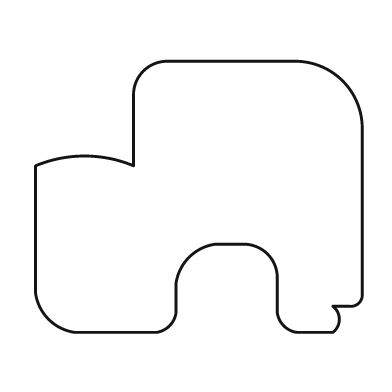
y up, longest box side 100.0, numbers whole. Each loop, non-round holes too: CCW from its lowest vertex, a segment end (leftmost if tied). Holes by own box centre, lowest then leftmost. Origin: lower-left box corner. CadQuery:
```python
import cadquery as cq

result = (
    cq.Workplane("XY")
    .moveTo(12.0, 0.0)
    .lineTo(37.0, 0.0)
    .threePointArc((41.0, 2.0), (43.0, 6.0))
    .lineTo(43.0, 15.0)
    .threePointArc((47.0, 23.0), (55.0, 27.0))
    .lineTo(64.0, 27.0)
    .threePointArc((71.0, 24.0), (74.0, 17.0))
    .lineTo(74.0, 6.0)
    .threePointArc((76.0, 2.0), (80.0, 0.0))
    .lineTo(91.0, 0.0)
    .threePointArc((93.0, 4.0), (91.0, 8.0))
    .lineTo(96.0, 8.0)
    .threePointArc((99.0, 9.0), (100.0, 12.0))
    .lineTo(100.0, 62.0)
    .threePointArc((94.0, 77.0), (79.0, 83.0))
    .lineTo(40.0, 83.0)
    .threePointArc((33.0, 80.0), (30.0, 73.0))
    .lineTo(30.0, 51.0)
    .threePointArc((15.0, 54.0), (0.0, 51.0))
    .lineTo(0.0, 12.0)
    .threePointArc((4.0, 4.0), (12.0, 0.0))
    .close()
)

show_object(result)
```